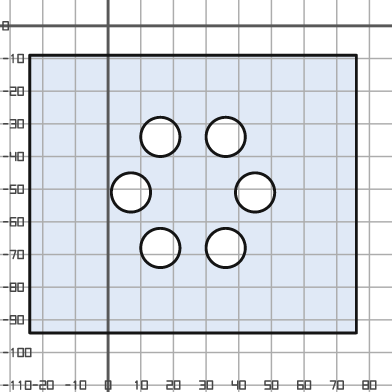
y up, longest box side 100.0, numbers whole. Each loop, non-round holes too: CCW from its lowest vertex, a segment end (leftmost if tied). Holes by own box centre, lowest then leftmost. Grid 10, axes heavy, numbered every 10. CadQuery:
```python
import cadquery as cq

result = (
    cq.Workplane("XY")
    .moveTo(-24.0, -94.0)
    .lineTo(76.0, -94.0)
    .lineTo(76.0, -9.0)
    .lineTo(-24.0, -9.0)
    .close()
    .moveTo(16.0, -68.0)
    .circle(6.0)
    .moveTo(36.0, -68.0)
    .circle(6.0)
    .moveTo(7.0, -51.0)
    .circle(6.0)
    .moveTo(45.0, -51.0)
    .circle(6.0)
    .moveTo(16.0, -34.0)
    .circle(6.0)
    .moveTo(36.0, -34.0)
    .circle(6.0)
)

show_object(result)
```